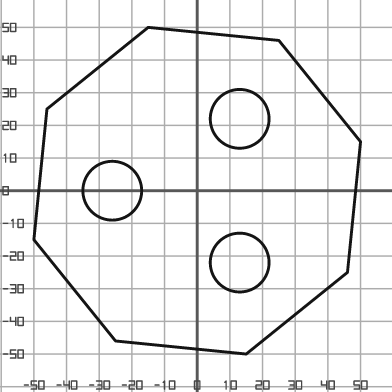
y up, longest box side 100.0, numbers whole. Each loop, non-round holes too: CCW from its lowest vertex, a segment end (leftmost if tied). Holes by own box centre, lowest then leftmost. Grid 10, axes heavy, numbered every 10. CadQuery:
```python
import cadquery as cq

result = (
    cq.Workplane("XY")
    .moveTo(15.0, -50.0)
    .lineTo(46.0, -25.0)
    .lineTo(50.0, 15.0)
    .lineTo(25.0, 46.0)
    .lineTo(-15.0, 50.0)
    .lineTo(-46.0, 25.0)
    .lineTo(-50.0, -15.0)
    .lineTo(-25.0, -46.0)
    .close()
    .moveTo(13.0, -22.0)
    .circle(9.0)
    .moveTo(-26.0, 0.0)
    .circle(9.0)
    .moveTo(13.0, 22.0)
    .circle(9.0)
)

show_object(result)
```